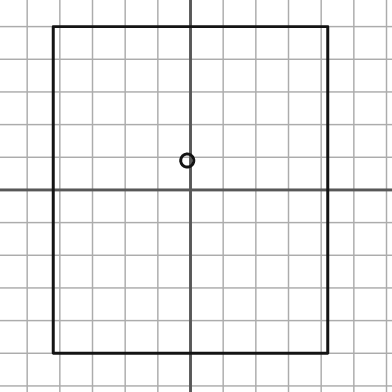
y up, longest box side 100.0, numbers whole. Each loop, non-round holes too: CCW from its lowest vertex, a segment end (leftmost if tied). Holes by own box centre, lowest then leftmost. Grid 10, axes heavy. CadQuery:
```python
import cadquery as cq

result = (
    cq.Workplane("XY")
    .moveTo(-42.0, -50.0)
    .lineTo(42.0, -50.0)
    .lineTo(42.0, 50.0)
    .lineTo(-42.0, 50.0)
    .close()
    .moveTo(-1.0, 9.0)
    .circle(2.0)
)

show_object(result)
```